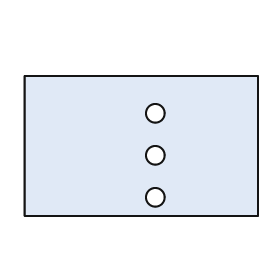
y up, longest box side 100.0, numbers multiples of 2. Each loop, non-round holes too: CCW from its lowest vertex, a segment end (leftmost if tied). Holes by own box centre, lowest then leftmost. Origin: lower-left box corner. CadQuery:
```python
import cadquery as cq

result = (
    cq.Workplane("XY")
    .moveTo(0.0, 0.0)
    .lineTo(100.0, 0.0)
    .lineTo(100.0, 60.0)
    .lineTo(0.0, 60.0)
    .close()
    .moveTo(56.0, 8.0)
    .circle(4.0)
    .moveTo(56.0, 26.0)
    .circle(4.0)
    .moveTo(56.0, 44.0)
    .circle(4.0)
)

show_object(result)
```